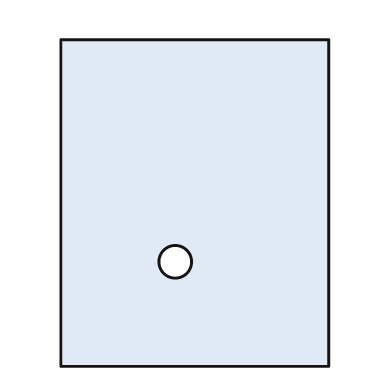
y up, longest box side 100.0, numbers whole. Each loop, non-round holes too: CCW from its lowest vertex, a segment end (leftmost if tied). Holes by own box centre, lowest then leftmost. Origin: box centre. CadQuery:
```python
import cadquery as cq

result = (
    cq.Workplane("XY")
    .moveTo(-41.0, -50.0)
    .lineTo(41.0, -50.0)
    .lineTo(41.0, 50.0)
    .lineTo(-41.0, 50.0)
    .close()
    .moveTo(-6.0, -18.0)
    .circle(5.0)
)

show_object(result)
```